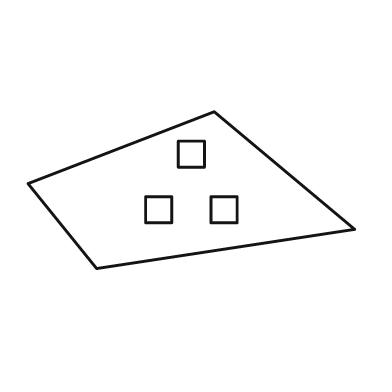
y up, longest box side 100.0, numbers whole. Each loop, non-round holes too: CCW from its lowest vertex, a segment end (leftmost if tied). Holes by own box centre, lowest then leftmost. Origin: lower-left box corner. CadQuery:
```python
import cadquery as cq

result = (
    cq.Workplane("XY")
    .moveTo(21.0, 0.0)
    .lineTo(100.0, 12.0)
    .lineTo(57.0, 48.0)
    .lineTo(0.0, 26.0)
    .close()
    .moveTo(36.0, 14.0)
    .lineTo(44.0, 14.0)
    .lineTo(44.0, 22.0)
    .lineTo(36.0, 22.0)
    .close()
    .moveTo(56.0, 14.0)
    .lineTo(64.0, 14.0)
    .lineTo(64.0, 22.0)
    .lineTo(56.0, 22.0)
    .close()
    .moveTo(46.0, 31.0)
    .lineTo(54.0, 31.0)
    .lineTo(54.0, 39.0)
    .lineTo(46.0, 39.0)
    .close()
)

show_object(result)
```